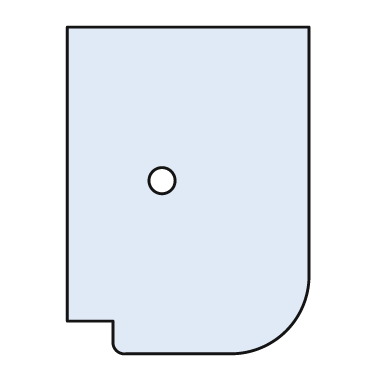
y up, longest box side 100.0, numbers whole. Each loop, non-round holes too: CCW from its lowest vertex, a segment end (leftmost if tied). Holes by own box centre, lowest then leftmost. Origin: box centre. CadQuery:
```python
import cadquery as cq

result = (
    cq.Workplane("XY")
    .moveTo(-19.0, -50.0)
    .lineTo(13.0, -50.0)
    .threePointArc((30.0, -43.0), (37.0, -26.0))
    .lineTo(37.0, 50.0)
    .lineTo(-37.0, 50.0)
    .lineTo(-37.0, -40.0)
    .lineTo(-23.0, -40.0)
    .lineTo(-23.0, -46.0)
    .threePointArc((-22.0, -49.0), (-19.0, -50.0))
    .close()
    .moveTo(-8.0, 3.0)
    .circle(4.0)
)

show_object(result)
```